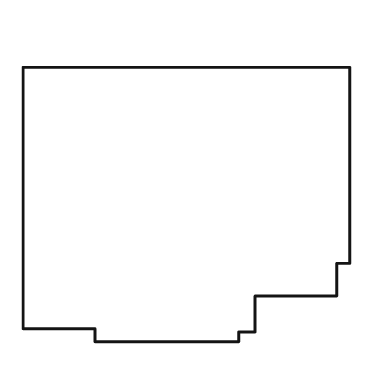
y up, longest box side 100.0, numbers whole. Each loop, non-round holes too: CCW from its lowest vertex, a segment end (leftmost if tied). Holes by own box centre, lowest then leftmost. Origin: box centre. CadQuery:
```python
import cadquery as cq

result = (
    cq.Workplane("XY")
    .moveTo(-28.0, -42.0)
    .lineTo(16.0, -42.0)
    .lineTo(16.0, -39.0)
    .lineTo(21.0, -39.0)
    .lineTo(21.0, -28.0)
    .lineTo(46.0, -28.0)
    .lineTo(46.0, -18.0)
    .lineTo(50.0, -18.0)
    .lineTo(50.0, 42.0)
    .lineTo(-50.0, 42.0)
    .lineTo(-50.0, -38.0)
    .lineTo(-28.0, -38.0)
    .close()
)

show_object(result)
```